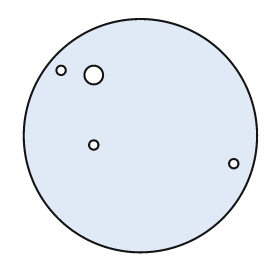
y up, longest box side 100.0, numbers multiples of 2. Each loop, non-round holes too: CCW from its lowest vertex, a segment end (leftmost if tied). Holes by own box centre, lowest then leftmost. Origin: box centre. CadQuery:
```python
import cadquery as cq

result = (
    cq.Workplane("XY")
    .moveTo(0.0, 0.0)
    .circle(50.0)
    .moveTo(40.0, -12.0)
    .circle(2.0)
    .moveTo(-20.0, -4.0)
    .circle(2.0)
    .moveTo(-20.0, 26.0)
    .circle(4.0)
    .moveTo(-34.0, 28.0)
    .circle(2.0)
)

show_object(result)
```